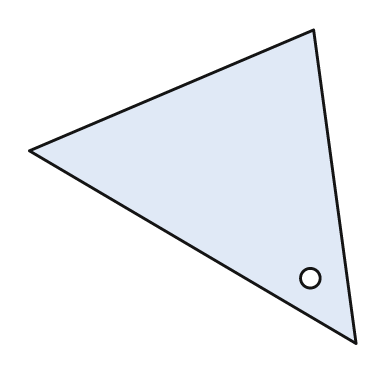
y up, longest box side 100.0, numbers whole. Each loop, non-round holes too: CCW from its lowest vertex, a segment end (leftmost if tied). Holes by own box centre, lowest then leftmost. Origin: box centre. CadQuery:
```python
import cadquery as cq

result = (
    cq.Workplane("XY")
    .moveTo(50.0, -48.0)
    .lineTo(37.0, 48.0)
    .lineTo(-50.0, 11.0)
    .close()
    .moveTo(36.0, -28.0)
    .circle(3.0)
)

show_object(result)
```